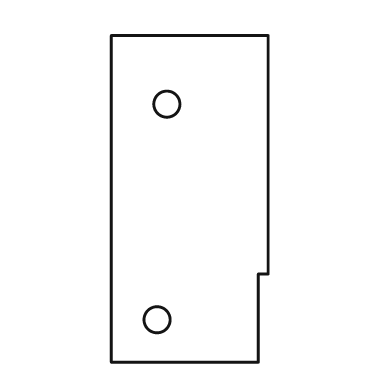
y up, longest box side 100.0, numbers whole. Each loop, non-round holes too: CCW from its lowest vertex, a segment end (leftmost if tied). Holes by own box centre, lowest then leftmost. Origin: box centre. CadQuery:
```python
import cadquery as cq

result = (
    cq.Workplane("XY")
    .moveTo(-24.0, -50.0)
    .lineTo(21.0, -50.0)
    .lineTo(21.0, -23.0)
    .lineTo(24.0, -23.0)
    .lineTo(24.0, 50.0)
    .lineTo(-24.0, 50.0)
    .close()
    .moveTo(-10.0, -37.0)
    .circle(4.0)
    .moveTo(-7.0, 29.0)
    .circle(4.0)
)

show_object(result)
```